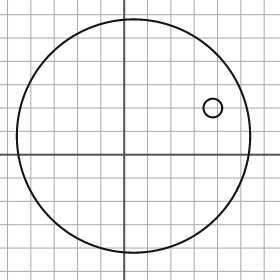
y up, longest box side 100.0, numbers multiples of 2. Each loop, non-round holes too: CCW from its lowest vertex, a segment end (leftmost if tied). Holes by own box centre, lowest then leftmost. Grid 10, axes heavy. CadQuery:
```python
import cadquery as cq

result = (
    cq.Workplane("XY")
    .moveTo(4.0, 8.0)
    .circle(50.0)
    .moveTo(38.0, 20.0)
    .circle(4.0)
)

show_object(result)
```